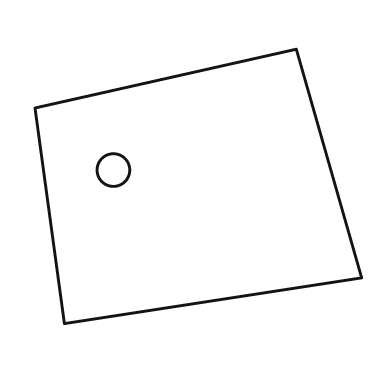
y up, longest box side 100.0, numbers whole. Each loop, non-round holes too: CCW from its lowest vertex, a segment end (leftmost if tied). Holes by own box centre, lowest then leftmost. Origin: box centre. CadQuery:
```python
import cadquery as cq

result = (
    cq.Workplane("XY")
    .moveTo(-41.0, -42.0)
    .lineTo(50.0, -28.0)
    .lineTo(30.0, 42.0)
    .lineTo(-50.0, 24.0)
    .close()
    .moveTo(-26.0, 5.0)
    .circle(5.0)
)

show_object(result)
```